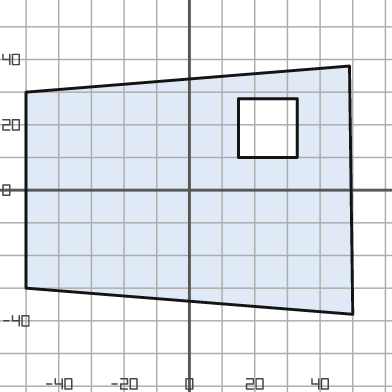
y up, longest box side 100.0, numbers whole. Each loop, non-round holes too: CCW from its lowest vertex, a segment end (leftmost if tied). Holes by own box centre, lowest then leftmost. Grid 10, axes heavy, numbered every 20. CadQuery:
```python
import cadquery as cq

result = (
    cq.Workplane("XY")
    .moveTo(50.0, -38.0)
    .lineTo(49.0, 38.0)
    .lineTo(-50.0, 30.0)
    .lineTo(-50.0, -30.0)
    .close()
    .moveTo(15.0, 10.0)
    .lineTo(33.0, 10.0)
    .lineTo(33.0, 28.0)
    .lineTo(15.0, 28.0)
    .close()
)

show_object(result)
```